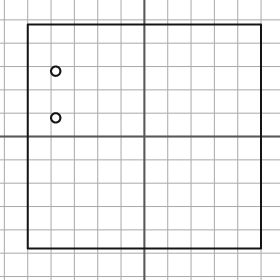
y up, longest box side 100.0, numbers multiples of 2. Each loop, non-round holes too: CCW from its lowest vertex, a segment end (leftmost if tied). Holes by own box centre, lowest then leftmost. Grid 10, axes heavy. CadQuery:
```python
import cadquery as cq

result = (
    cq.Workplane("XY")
    .moveTo(-50.0, -48.0)
    .lineTo(50.0, -48.0)
    .lineTo(50.0, 48.0)
    .lineTo(-50.0, 48.0)
    .close()
    .moveTo(-38.0, 8.0)
    .circle(2.0)
    .moveTo(-38.0, 28.0)
    .circle(2.0)
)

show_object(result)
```